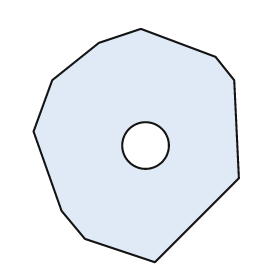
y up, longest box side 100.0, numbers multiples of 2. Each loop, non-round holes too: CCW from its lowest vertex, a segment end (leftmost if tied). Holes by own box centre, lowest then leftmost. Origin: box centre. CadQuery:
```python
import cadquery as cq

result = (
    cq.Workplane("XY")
    .moveTo(8.0, -50.0)
    .lineTo(44.0, -14.0)
    .lineTo(42.0, 28.0)
    .lineTo(34.0, 38.0)
    .lineTo(2.0, 50.0)
    .lineTo(-16.0, 44.0)
    .lineTo(-36.0, 28.0)
    .lineTo(-44.0, 6.0)
    .lineTo(-32.0, -28.0)
    .lineTo(-22.0, -40.0)
    .close()
    .moveTo(4.0, 0.0)
    .circle(10.0)
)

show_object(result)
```